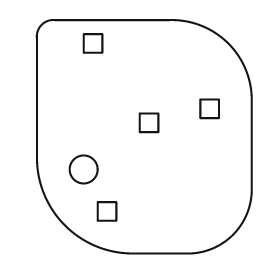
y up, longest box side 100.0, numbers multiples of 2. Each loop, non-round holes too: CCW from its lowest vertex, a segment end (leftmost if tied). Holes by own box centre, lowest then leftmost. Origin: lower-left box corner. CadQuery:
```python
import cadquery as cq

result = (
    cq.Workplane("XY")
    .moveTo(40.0, 0.0)
    .lineTo(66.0, 0.0)
    .threePointArc((84.0, 8.0), (92.0, 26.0))
    .lineTo(92.0, 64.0)
    .threePointArc((82.0, 90.0), (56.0, 100.0))
    .lineTo(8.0, 100.0)
    .threePointArc((2.0, 98.0), (0.0, 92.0))
    .lineTo(0.0, 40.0)
    .threePointArc((12.0, 12.0), (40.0, 0.0))
    .close()
    .moveTo(26.0, 14.0)
    .lineTo(34.0, 14.0)
    .lineTo(34.0, 22.0)
    .lineTo(26.0, 22.0)
    .close()
    .moveTo(20.0, 36.0)
    .circle(6.0)
    .moveTo(44.0, 52.0)
    .lineTo(52.0, 52.0)
    .lineTo(52.0, 60.0)
    .lineTo(44.0, 60.0)
    .close()
    .moveTo(70.0, 58.0)
    .lineTo(78.0, 58.0)
    .lineTo(78.0, 66.0)
    .lineTo(70.0, 66.0)
    .close()
    .moveTo(20.0, 86.0)
    .lineTo(28.0, 86.0)
    .lineTo(28.0, 94.0)
    .lineTo(20.0, 94.0)
    .close()
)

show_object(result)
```